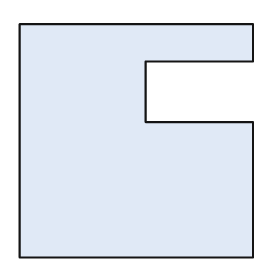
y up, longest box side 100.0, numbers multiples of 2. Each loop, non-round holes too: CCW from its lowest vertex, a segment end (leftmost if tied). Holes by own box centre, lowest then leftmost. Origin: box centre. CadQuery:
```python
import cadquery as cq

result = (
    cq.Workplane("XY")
    .moveTo(-50.0, -50.0)
    .lineTo(50.0, -50.0)
    .lineTo(50.0, 8.0)
    .lineTo(4.0, 8.0)
    .lineTo(4.0, 34.0)
    .lineTo(50.0, 34.0)
    .lineTo(50.0, 50.0)
    .lineTo(-50.0, 50.0)
    .close()
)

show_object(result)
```